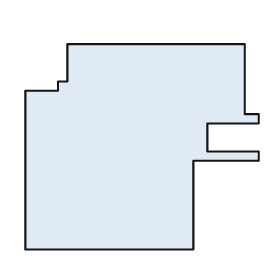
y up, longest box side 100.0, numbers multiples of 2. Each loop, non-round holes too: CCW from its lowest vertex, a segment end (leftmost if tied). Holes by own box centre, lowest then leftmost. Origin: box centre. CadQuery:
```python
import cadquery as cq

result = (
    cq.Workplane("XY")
    .moveTo(-50.0, -44.0)
    .lineTo(22.0, -44.0)
    .lineTo(22.0, -6.0)
    .lineTo(50.0, -6.0)
    .lineTo(50.0, -2.0)
    .lineTo(28.0, -2.0)
    .lineTo(28.0, 10.0)
    .lineTo(50.0, 10.0)
    .lineTo(50.0, 14.0)
    .lineTo(44.0, 14.0)
    .lineTo(44.0, 44.0)
    .lineTo(-32.0, 44.0)
    .lineTo(-32.0, 28.0)
    .lineTo(-36.0, 28.0)
    .lineTo(-36.0, 24.0)
    .lineTo(-50.0, 24.0)
    .close()
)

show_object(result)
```